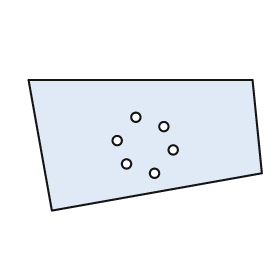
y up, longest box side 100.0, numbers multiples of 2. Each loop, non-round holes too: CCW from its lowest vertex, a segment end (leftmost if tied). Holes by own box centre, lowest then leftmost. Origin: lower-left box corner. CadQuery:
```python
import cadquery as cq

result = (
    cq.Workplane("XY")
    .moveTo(10.0, 0.0)
    .lineTo(100.0, 16.0)
    .lineTo(96.0, 56.0)
    .lineTo(0.0, 56.0)
    .close()
    .moveTo(54.0, 16.0)
    .circle(2.0)
    .moveTo(42.0, 20.0)
    .circle(2.0)
    .moveTo(62.0, 26.0)
    .circle(2.0)
    .moveTo(38.0, 30.0)
    .circle(2.0)
    .moveTo(58.0, 36.0)
    .circle(2.0)
    .moveTo(46.0, 40.0)
    .circle(2.0)
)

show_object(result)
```